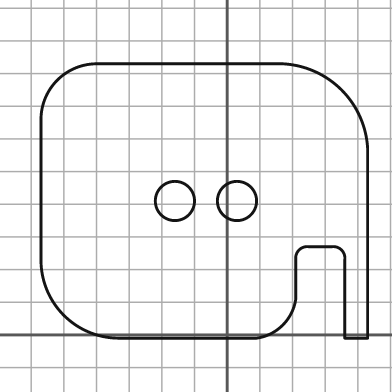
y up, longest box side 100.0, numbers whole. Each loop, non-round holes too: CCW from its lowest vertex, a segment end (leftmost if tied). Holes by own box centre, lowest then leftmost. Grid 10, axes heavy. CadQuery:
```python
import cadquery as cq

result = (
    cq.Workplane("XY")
    .moveTo(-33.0, -1.0)
    .lineTo(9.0, -1.0)
    .threePointArc((17.0, 3.0), (21.0, 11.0))
    .lineTo(21.0, 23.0)
    .threePointArc((22.0, 26.0), (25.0, 27.0))
    .lineTo(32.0, 27.0)
    .threePointArc((35.0, 26.0), (36.0, 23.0))
    .lineTo(36.0, -1.0)
    .lineTo(43.0, -1.0)
    .lineTo(43.0, 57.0)
    .threePointArc((35.0, 75.0), (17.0, 83.0))
    .lineTo(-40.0, 83.0)
    .threePointArc((-52.0, 78.0), (-57.0, 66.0))
    .lineTo(-57.0, 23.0)
    .threePointArc((-50.0, 6.0), (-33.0, -1.0))
    .close()
    .moveTo(-16.0, 41.0)
    .circle(6.0)
    .moveTo(3.0, 41.0)
    .circle(6.0)
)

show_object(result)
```